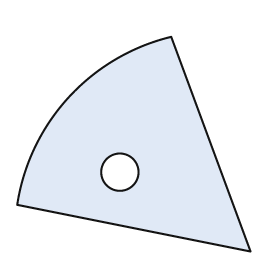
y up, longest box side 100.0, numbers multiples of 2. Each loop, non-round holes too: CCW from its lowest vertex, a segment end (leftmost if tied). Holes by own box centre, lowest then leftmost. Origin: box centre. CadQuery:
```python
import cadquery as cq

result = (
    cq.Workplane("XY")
    .moveTo(50.0, -46.0)
    .lineTo(16.0, 46.0)
    .threePointArc((-28.0, 20.0), (-50.0, -26.0))
    .close()
    .moveTo(-6.0, -12.0)
    .circle(8.0)
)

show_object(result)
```